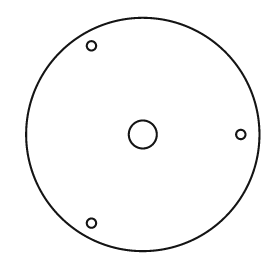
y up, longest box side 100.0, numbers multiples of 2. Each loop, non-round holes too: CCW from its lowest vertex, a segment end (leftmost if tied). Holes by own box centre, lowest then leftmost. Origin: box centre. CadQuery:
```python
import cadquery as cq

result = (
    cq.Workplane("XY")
    .moveTo(0.0, 0.0)
    .circle(50.0)
    .moveTo(-22.0, -38.0)
    .circle(2.0)
    .moveTo(0.0, 0.0)
    .circle(6.0)
    .moveTo(42.0, 0.0)
    .circle(2.0)
    .moveTo(-22.0, 38.0)
    .circle(2.0)
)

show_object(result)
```